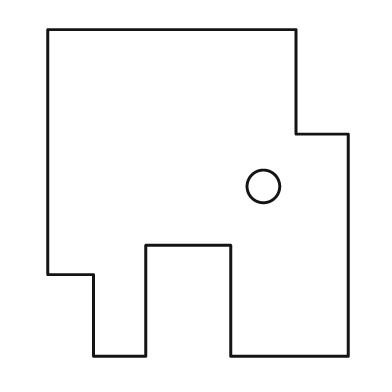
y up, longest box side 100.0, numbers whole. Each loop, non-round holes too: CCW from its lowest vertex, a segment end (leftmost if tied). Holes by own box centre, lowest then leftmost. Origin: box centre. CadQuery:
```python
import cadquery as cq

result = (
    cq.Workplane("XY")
    .moveTo(-32.0, -50.0)
    .lineTo(-16.0, -50.0)
    .lineTo(-16.0, -16.0)
    .lineTo(10.0, -16.0)
    .lineTo(10.0, -50.0)
    .lineTo(46.0, -50.0)
    .lineTo(46.0, 18.0)
    .lineTo(30.0, 18.0)
    .lineTo(30.0, 50.0)
    .lineTo(-46.0, 50.0)
    .lineTo(-46.0, -25.0)
    .lineTo(-32.0, -25.0)
    .close()
    .moveTo(20.0, 2.0)
    .circle(5.0)
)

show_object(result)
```